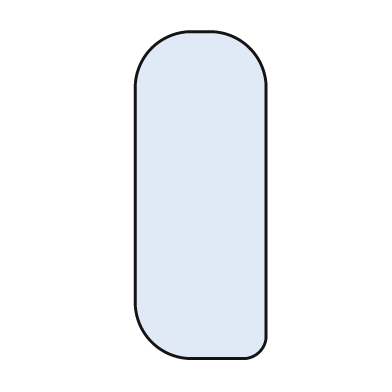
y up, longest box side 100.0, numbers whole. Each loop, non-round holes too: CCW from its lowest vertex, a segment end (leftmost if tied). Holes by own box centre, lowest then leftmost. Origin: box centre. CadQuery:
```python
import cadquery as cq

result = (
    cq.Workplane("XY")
    .moveTo(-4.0, -50.0)
    .lineTo(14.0, -50.0)
    .threePointArc((18.0, -48.0), (20.0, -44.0))
    .lineTo(20.0, 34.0)
    .threePointArc((15.0, 45.0), (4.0, 50.0))
    .lineTo(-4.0, 50.0)
    .threePointArc((-15.0, 45.0), (-20.0, 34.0))
    .lineTo(-20.0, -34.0)
    .threePointArc((-15.0, -45.0), (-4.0, -50.0))
    .close()
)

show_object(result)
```